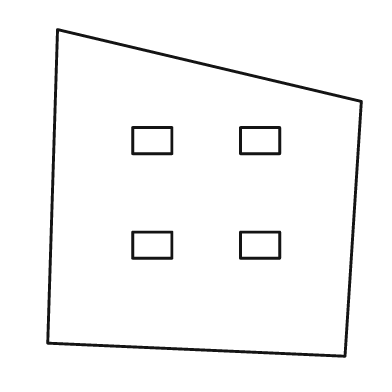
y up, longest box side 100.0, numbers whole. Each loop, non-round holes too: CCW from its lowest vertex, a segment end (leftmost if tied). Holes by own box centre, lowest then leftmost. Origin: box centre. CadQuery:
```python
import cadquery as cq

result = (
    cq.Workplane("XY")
    .moveTo(43.0, -50.0)
    .lineTo(48.0, 28.0)
    .lineTo(-45.0, 50.0)
    .lineTo(-48.0, -46.0)
    .close()
    .moveTo(-22.0, -20.0)
    .lineTo(-10.0, -20.0)
    .lineTo(-10.0, -12.0)
    .lineTo(-22.0, -12.0)
    .close()
    .moveTo(11.0, -20.0)
    .lineTo(23.0, -20.0)
    .lineTo(23.0, -12.0)
    .lineTo(11.0, -12.0)
    .close()
    .moveTo(-22.0, 12.0)
    .lineTo(-10.0, 12.0)
    .lineTo(-10.0, 20.0)
    .lineTo(-22.0, 20.0)
    .close()
    .moveTo(11.0, 12.0)
    .lineTo(23.0, 12.0)
    .lineTo(23.0, 20.0)
    .lineTo(11.0, 20.0)
    .close()
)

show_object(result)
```